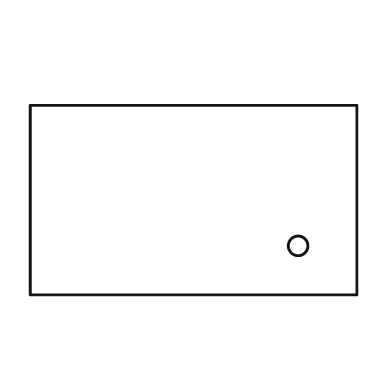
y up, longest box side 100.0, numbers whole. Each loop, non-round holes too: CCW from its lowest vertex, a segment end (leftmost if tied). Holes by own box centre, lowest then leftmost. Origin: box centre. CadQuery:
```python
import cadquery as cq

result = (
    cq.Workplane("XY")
    .moveTo(-50.0, -29.0)
    .lineTo(50.0, -29.0)
    .lineTo(50.0, 29.0)
    .lineTo(-50.0, 29.0)
    .close()
    .moveTo(32.0, -14.0)
    .circle(3.0)
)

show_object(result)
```